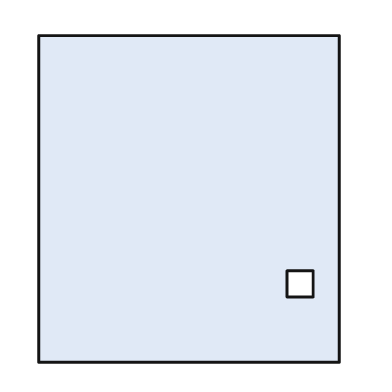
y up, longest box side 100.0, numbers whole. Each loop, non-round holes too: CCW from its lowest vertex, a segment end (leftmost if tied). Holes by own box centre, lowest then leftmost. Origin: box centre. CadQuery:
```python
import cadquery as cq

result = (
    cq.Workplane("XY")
    .moveTo(-46.0, -50.0)
    .lineTo(46.0, -50.0)
    .lineTo(46.0, 50.0)
    .lineTo(-46.0, 50.0)
    .close()
    .moveTo(30.0, -30.0)
    .lineTo(38.0, -30.0)
    .lineTo(38.0, -22.0)
    .lineTo(30.0, -22.0)
    .close()
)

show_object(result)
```